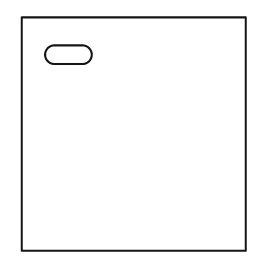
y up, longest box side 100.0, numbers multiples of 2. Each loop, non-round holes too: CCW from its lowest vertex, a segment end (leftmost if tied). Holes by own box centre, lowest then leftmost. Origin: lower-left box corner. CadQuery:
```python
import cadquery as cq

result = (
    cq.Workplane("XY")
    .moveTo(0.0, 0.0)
    .lineTo(96.0, 0.0)
    .lineTo(96.0, 100.0)
    .lineTo(0.0, 100.0)
    .close()
    .moveTo(14.0, 80.0)
    .lineTo(26.0, 80.0)
    .threePointArc((30.0, 84.0), (26.0, 88.0))
    .lineTo(14.0, 88.0)
    .threePointArc((10.0, 84.0), (14.0, 80.0))
    .close()
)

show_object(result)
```